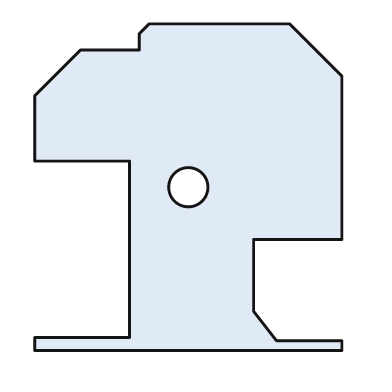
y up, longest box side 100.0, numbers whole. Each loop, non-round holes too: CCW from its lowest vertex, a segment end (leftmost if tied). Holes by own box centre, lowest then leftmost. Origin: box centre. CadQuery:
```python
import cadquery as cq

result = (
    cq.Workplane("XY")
    .moveTo(-47.0, -50.0)
    .lineTo(47.0, -50.0)
    .lineTo(47.0, -47.0)
    .lineTo(27.0, -47.0)
    .lineTo(20.0, -38.0)
    .lineTo(20.0, -16.0)
    .lineTo(47.0, -16.0)
    .lineTo(47.0, 34.0)
    .lineTo(31.0, 50.0)
    .lineTo(-12.0, 50.0)
    .lineTo(-15.0, 47.0)
    .lineTo(-15.0, 42.0)
    .lineTo(-33.0, 42.0)
    .lineTo(-47.0, 28.0)
    .lineTo(-47.0, 8.0)
    .lineTo(-18.0, 8.0)
    .lineTo(-18.0, -46.0)
    .lineTo(-47.0, -46.0)
    .close()
    .moveTo(0.0, 0.0)
    .circle(6.0)
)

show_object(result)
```